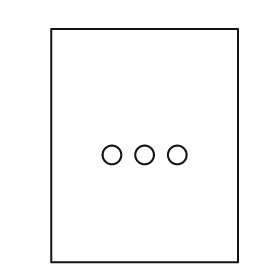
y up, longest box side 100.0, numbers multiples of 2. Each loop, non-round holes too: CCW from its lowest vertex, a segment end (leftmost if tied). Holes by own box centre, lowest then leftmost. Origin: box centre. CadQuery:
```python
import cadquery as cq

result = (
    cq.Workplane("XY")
    .moveTo(-40.0, -50.0)
    .lineTo(40.0, -50.0)
    .lineTo(40.0, 50.0)
    .lineTo(-40.0, 50.0)
    .close()
    .moveTo(-14.0, -4.0)
    .circle(4.0)
    .moveTo(0.0, -4.0)
    .circle(4.0)
    .moveTo(14.0, -4.0)
    .circle(4.0)
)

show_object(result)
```